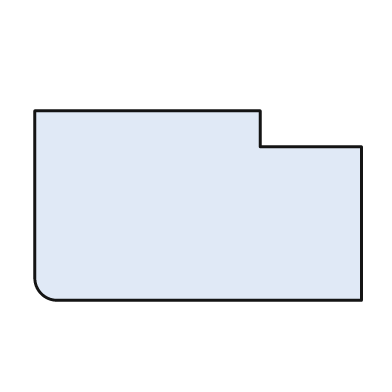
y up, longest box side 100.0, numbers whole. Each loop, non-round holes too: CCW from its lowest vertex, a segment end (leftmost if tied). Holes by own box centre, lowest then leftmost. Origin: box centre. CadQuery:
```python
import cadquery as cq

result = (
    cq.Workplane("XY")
    .moveTo(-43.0, -29.0)
    .lineTo(50.0, -29.0)
    .lineTo(50.0, 18.0)
    .lineTo(19.0, 18.0)
    .lineTo(19.0, 29.0)
    .lineTo(-50.0, 29.0)
    .lineTo(-50.0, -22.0)
    .threePointArc((-48.0, -27.0), (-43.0, -29.0))
    .close()
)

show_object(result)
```